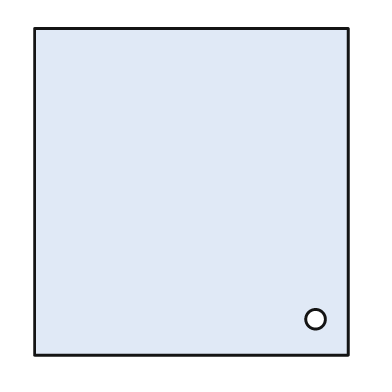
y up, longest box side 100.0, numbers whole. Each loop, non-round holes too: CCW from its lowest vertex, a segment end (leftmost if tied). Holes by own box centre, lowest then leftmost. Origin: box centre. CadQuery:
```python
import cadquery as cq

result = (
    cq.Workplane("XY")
    .moveTo(-48.0, -50.0)
    .lineTo(48.0, -50.0)
    .lineTo(48.0, 50.0)
    .lineTo(-48.0, 50.0)
    .close()
    .moveTo(38.0, -39.0)
    .circle(3.0)
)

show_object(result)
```